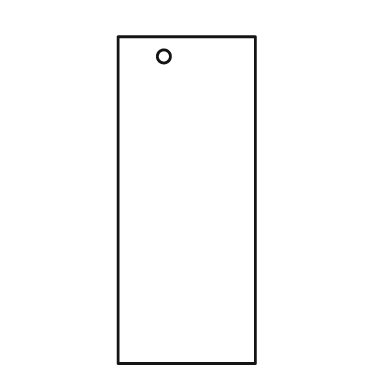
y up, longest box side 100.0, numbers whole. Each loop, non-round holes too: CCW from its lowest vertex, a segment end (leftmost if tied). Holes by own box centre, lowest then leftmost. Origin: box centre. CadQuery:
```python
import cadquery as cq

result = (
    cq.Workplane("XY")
    .moveTo(-21.0, -50.0)
    .lineTo(21.0, -50.0)
    .lineTo(21.0, 50.0)
    .lineTo(-21.0, 50.0)
    .close()
    .moveTo(-7.0, 44.0)
    .circle(2.0)
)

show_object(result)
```